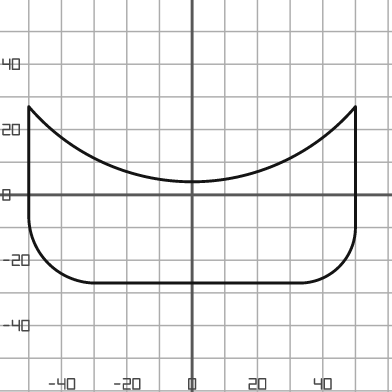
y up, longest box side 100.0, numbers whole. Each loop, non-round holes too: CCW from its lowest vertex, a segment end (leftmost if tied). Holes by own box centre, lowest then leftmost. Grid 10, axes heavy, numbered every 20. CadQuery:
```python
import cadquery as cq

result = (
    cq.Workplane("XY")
    .moveTo(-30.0, -27.0)
    .lineTo(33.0, -27.0)
    .threePointArc((45.0, -22.0), (50.0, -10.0))
    .lineTo(50.0, 27.0)
    .threePointArc((0.0, 4.0), (-50.0, 27.0))
    .lineTo(-50.0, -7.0)
    .threePointArc((-44.0, -21.0), (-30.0, -27.0))
    .close()
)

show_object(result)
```